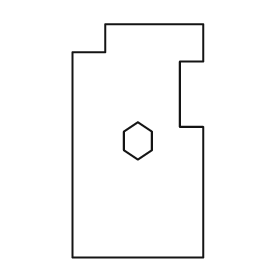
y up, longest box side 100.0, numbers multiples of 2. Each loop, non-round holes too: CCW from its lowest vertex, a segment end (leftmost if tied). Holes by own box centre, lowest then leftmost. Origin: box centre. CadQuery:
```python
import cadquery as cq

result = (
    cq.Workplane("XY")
    .moveTo(-28.0, -50.0)
    .lineTo(28.0, -50.0)
    .lineTo(28.0, 6.0)
    .lineTo(18.0, 6.0)
    .lineTo(18.0, 34.0)
    .lineTo(28.0, 34.0)
    .lineTo(28.0, 50.0)
    .lineTo(-14.0, 50.0)
    .lineTo(-14.0, 38.0)
    .lineTo(-28.0, 38.0)
    .close()
    .moveTo(0.0, -8.0)
    .lineTo(6.0, -4.0)
    .lineTo(6.0, 4.0)
    .lineTo(0.0, 8.0)
    .lineTo(-6.0, 4.0)
    .lineTo(-6.0, -4.0)
    .close()
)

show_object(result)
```